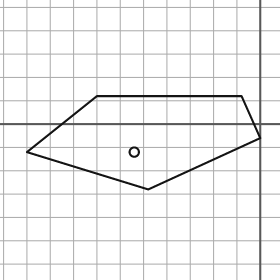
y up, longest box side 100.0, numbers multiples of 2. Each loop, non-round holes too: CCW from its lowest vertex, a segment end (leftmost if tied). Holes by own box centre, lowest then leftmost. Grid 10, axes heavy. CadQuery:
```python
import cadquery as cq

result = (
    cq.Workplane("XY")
    .moveTo(-48.0, -28.0)
    .lineTo(0.0, -6.0)
    .lineTo(-8.0, 12.0)
    .lineTo(-70.0, 12.0)
    .lineTo(-100.0, -12.0)
    .close()
    .moveTo(-54.0, -12.0)
    .circle(2.0)
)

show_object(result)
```